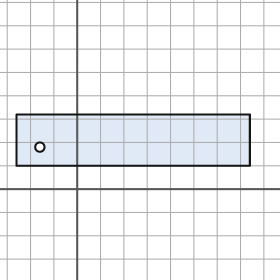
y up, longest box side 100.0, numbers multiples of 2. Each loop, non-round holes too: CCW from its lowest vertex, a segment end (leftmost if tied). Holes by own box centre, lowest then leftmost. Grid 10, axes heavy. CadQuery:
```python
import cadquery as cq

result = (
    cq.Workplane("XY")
    .moveTo(-26.0, 10.0)
    .lineTo(74.0, 10.0)
    .lineTo(74.0, 32.0)
    .lineTo(-26.0, 32.0)
    .close()
    .moveTo(-16.0, 18.0)
    .circle(2.0)
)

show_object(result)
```